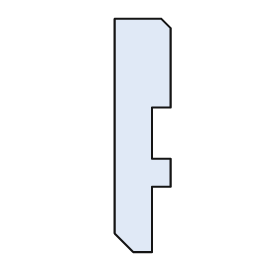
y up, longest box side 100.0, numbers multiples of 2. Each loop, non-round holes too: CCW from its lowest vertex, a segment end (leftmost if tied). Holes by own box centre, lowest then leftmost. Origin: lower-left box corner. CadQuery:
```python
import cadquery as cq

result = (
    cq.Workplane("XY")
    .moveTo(8.0, 0.0)
    .lineTo(16.0, 0.0)
    .lineTo(16.0, 28.0)
    .lineTo(24.0, 28.0)
    .lineTo(24.0, 40.0)
    .lineTo(16.0, 40.0)
    .lineTo(16.0, 62.0)
    .lineTo(24.0, 62.0)
    .lineTo(24.0, 96.0)
    .lineTo(20.0, 100.0)
    .lineTo(0.0, 100.0)
    .lineTo(0.0, 8.0)
    .close()
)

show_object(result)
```